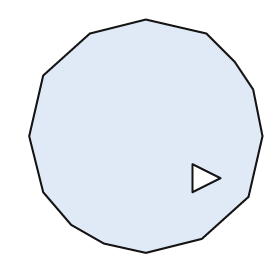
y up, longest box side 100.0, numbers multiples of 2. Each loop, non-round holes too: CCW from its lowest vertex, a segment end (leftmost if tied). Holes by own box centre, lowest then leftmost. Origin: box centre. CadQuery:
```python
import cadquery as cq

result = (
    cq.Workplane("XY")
    .moveTo(0.0, -50.0)
    .lineTo(24.0, -44.0)
    .lineTo(44.0, -26.0)
    .lineTo(50.0, 0.0)
    .lineTo(46.0, 20.0)
    .lineTo(38.0, 32.0)
    .lineTo(26.0, 44.0)
    .lineTo(0.0, 50.0)
    .lineTo(-24.0, 44.0)
    .lineTo(-44.0, 26.0)
    .lineTo(-50.0, 0.0)
    .lineTo(-44.0, -24.0)
    .lineTo(-32.0, -38.0)
    .lineTo(-18.0, -46.0)
    .close()
    .moveTo(20.0, -24.0)
    .lineTo(32.0, -18.0)
    .lineTo(20.0, -12.0)
    .close()
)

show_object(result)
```